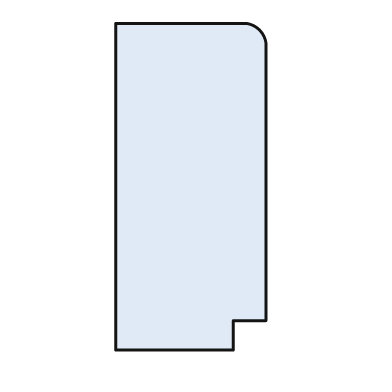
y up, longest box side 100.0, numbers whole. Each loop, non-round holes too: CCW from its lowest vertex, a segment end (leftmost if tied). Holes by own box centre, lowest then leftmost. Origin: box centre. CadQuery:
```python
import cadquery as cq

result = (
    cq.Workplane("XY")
    .moveTo(-23.0, -50.0)
    .lineTo(13.0, -50.0)
    .lineTo(13.0, -41.0)
    .lineTo(23.0, -41.0)
    .lineTo(23.0, 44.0)
    .threePointArc((21.0, 48.0), (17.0, 50.0))
    .lineTo(-23.0, 50.0)
    .close()
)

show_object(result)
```